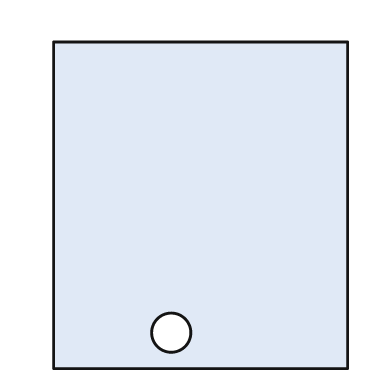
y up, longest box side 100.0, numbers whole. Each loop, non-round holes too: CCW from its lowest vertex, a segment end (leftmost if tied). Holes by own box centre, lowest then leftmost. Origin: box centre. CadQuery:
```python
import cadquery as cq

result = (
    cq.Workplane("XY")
    .moveTo(-45.0, -50.0)
    .lineTo(45.0, -50.0)
    .lineTo(45.0, 50.0)
    .lineTo(-45.0, 50.0)
    .close()
    .moveTo(-9.0, -39.0)
    .circle(6.0)
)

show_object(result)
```